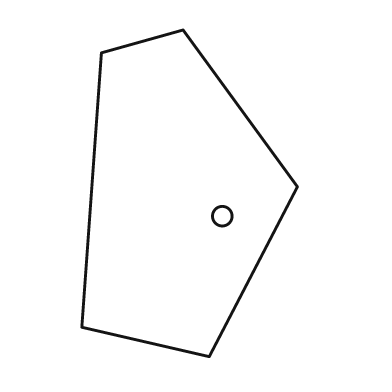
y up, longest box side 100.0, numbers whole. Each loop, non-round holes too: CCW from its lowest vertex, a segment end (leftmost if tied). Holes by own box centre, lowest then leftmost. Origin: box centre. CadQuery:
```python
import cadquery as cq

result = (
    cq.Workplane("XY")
    .moveTo(6.0, -50.0)
    .lineTo(33.0, 2.0)
    .lineTo(-2.0, 50.0)
    .lineTo(-27.0, 43.0)
    .lineTo(-33.0, -41.0)
    .close()
    .moveTo(10.0, -7.0)
    .circle(3.0)
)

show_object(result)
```